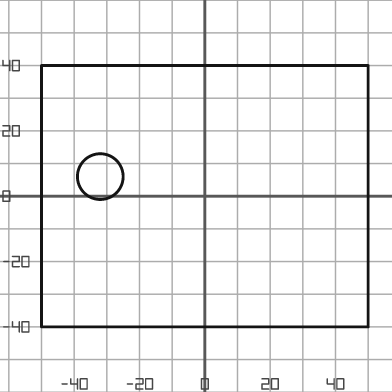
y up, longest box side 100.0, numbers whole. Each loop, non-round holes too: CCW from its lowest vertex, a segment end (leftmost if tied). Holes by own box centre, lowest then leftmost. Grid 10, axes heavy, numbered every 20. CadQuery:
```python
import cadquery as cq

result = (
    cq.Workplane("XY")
    .moveTo(-50.0, -40.0)
    .lineTo(50.0, -40.0)
    .lineTo(50.0, 40.0)
    .lineTo(-50.0, 40.0)
    .close()
    .moveTo(-32.0, 6.0)
    .circle(7.0)
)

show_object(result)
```